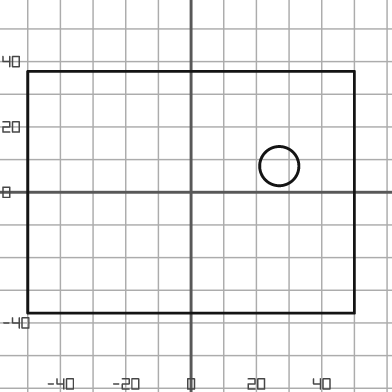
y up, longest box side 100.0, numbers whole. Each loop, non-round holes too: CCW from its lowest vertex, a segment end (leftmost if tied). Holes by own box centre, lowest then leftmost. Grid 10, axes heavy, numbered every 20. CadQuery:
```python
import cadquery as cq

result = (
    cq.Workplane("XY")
    .moveTo(-50.0, -37.0)
    .lineTo(50.0, -37.0)
    .lineTo(50.0, 37.0)
    .lineTo(-50.0, 37.0)
    .close()
    .moveTo(27.0, 8.0)
    .circle(6.0)
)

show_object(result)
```